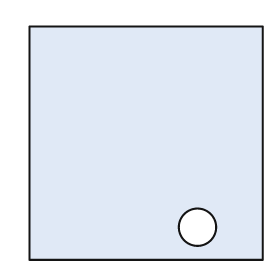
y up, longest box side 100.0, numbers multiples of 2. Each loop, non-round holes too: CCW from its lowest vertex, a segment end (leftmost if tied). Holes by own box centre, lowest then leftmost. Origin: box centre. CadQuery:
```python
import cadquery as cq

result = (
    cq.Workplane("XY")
    .moveTo(-50.0, -50.0)
    .lineTo(50.0, -50.0)
    .lineTo(50.0, 50.0)
    .lineTo(-50.0, 50.0)
    .close()
    .moveTo(22.0, -36.0)
    .circle(8.0)
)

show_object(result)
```